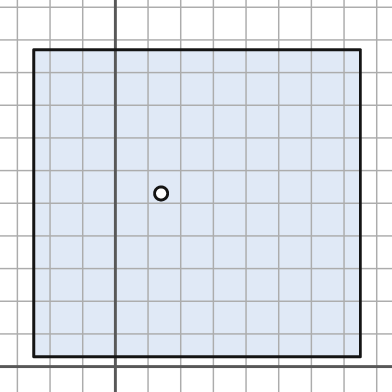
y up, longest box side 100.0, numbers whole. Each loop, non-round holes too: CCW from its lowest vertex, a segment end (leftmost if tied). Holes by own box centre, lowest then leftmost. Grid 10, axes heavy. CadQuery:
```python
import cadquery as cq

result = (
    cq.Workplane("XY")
    .moveTo(-25.0, 3.0)
    .lineTo(75.0, 3.0)
    .lineTo(75.0, 97.0)
    .lineTo(-25.0, 97.0)
    .close()
    .moveTo(14.0, 53.0)
    .circle(2.0)
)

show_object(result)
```